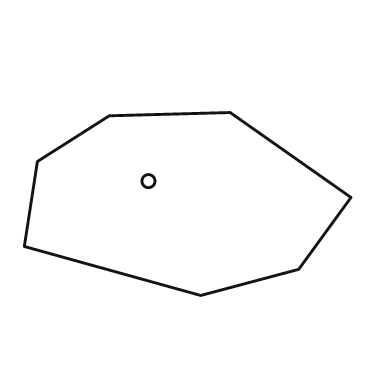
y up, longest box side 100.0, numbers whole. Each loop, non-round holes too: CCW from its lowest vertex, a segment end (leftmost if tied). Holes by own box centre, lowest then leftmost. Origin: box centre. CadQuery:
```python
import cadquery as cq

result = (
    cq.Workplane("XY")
    .moveTo(4.0, -28.0)
    .lineTo(34.0, -20.0)
    .lineTo(50.0, 2.0)
    .lineTo(13.0, 28.0)
    .lineTo(-24.0, 27.0)
    .lineTo(-46.0, 13.0)
    .lineTo(-50.0, -13.0)
    .close()
    .moveTo(-12.0, 7.0)
    .circle(2.0)
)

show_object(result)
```